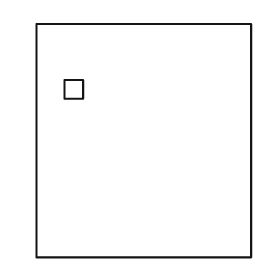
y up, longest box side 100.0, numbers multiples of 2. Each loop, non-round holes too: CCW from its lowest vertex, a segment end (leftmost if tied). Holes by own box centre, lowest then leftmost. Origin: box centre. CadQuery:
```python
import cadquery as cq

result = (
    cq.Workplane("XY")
    .moveTo(-46.0, -50.0)
    .lineTo(46.0, -50.0)
    .lineTo(46.0, 50.0)
    .lineTo(-46.0, 50.0)
    .close()
    .moveTo(-34.0, 18.0)
    .lineTo(-26.0, 18.0)
    .lineTo(-26.0, 26.0)
    .lineTo(-34.0, 26.0)
    .close()
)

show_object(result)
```